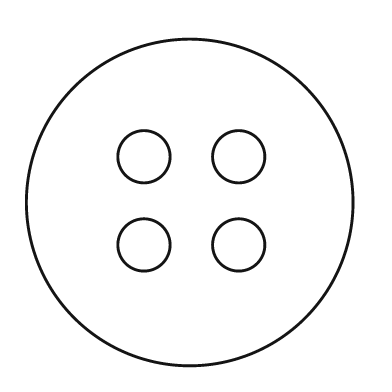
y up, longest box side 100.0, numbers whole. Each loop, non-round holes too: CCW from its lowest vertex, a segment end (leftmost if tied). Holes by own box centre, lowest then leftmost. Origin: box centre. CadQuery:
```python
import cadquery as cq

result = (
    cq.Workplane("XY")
    .moveTo(0.0, 0.0)
    .circle(50.0)
    .moveTo(-14.0, -13.0)
    .circle(8.0)
    .moveTo(15.0, -13.0)
    .circle(8.0)
    .moveTo(-14.0, 14.0)
    .circle(8.0)
    .moveTo(15.0, 14.0)
    .circle(8.0)
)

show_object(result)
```